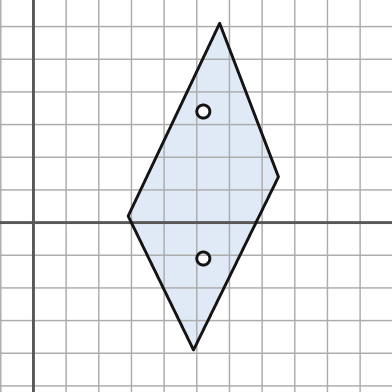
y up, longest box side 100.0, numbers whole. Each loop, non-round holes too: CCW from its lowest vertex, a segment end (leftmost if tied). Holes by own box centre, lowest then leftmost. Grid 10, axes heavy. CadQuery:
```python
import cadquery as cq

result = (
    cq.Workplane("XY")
    .moveTo(49.0, -39.0)
    .lineTo(75.0, 14.0)
    .lineTo(57.0, 61.0)
    .lineTo(29.0, 2.0)
    .close()
    .moveTo(52.0, -11.0)
    .circle(2.0)
    .moveTo(52.0, 34.0)
    .circle(2.0)
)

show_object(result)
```